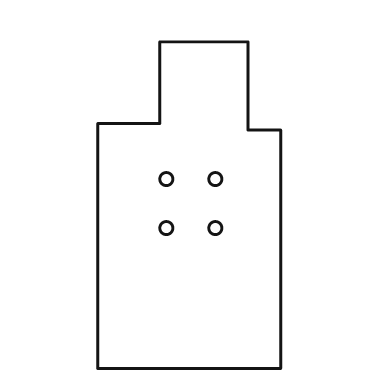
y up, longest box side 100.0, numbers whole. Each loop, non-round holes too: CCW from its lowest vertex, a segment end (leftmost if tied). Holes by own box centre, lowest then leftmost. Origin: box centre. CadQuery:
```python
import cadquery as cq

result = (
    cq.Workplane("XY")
    .moveTo(-28.0, -50.0)
    .lineTo(28.0, -50.0)
    .lineTo(28.0, 23.0)
    .lineTo(18.0, 23.0)
    .lineTo(18.0, 50.0)
    .lineTo(-9.0, 50.0)
    .lineTo(-9.0, 25.0)
    .lineTo(-28.0, 25.0)
    .close()
    .moveTo(-7.0, -7.0)
    .circle(2.0)
    .moveTo(8.0, -7.0)
    .circle(2.0)
    .moveTo(-7.0, 8.0)
    .circle(2.0)
    .moveTo(8.0, 8.0)
    .circle(2.0)
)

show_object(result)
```